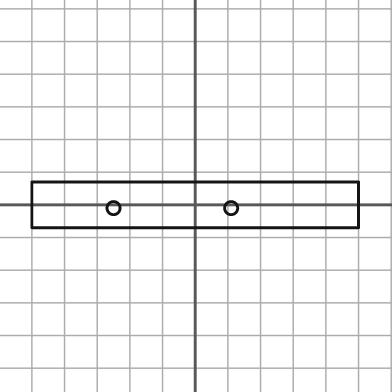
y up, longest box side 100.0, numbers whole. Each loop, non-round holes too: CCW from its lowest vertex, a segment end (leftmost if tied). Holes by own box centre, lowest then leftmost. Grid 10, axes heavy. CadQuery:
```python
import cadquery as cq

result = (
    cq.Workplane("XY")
    .moveTo(-50.0, -7.0)
    .lineTo(50.0, -7.0)
    .lineTo(50.0, 7.0)
    .lineTo(-50.0, 7.0)
    .close()
    .moveTo(-25.0, -1.0)
    .circle(2.0)
    .moveTo(11.0, -1.0)
    .circle(2.0)
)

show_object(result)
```